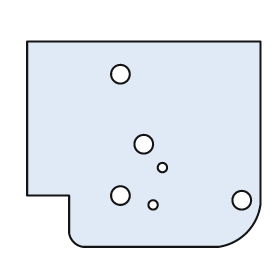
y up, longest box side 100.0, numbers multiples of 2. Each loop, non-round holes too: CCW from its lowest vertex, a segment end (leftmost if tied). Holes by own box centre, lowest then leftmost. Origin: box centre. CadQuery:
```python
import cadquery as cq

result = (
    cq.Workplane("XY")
    .moveTo(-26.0, -44.0)
    .lineTo(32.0, -44.0)
    .threePointArc((44.0, -38.0), (50.0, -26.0))
    .lineTo(50.0, 44.0)
    .lineTo(-50.0, 44.0)
    .lineTo(-50.0, -22.0)
    .lineTo(-32.0, -22.0)
    .lineTo(-32.0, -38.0)
    .threePointArc((-30.0, -42.0), (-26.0, -44.0))
    .close()
    .moveTo(4.0, -26.0)
    .circle(2.0)
    .moveTo(42.0, -24.0)
    .circle(4.0)
    .moveTo(-10.0, -22.0)
    .circle(4.0)
    .moveTo(8.0, -10.0)
    .circle(2.0)
    .moveTo(0.0, 0.0)
    .circle(4.0)
    .moveTo(-10.0, 30.0)
    .circle(4.0)
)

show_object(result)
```